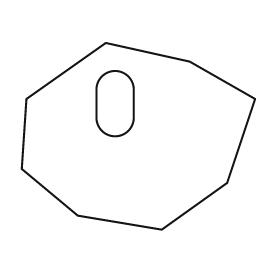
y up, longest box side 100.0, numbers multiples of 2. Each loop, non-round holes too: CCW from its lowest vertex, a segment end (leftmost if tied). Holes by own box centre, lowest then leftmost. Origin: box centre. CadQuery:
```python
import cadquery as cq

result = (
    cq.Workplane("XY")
    .moveTo(10.0, -40.0)
    .lineTo(38.0, -20.0)
    .lineTo(50.0, 16.0)
    .lineTo(22.0, 32.0)
    .lineTo(-14.0, 40.0)
    .lineTo(-48.0, 16.0)
    .lineTo(-50.0, -14.0)
    .lineTo(-26.0, -34.0)
    .close()
    .moveTo(-18.0, 8.0)
    .threePointArc((-10.0, 0.0), (-2.0, 8.0))
    .lineTo(-2.0, 20.0)
    .threePointArc((-10.0, 28.0), (-18.0, 20.0))
    .close()
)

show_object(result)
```